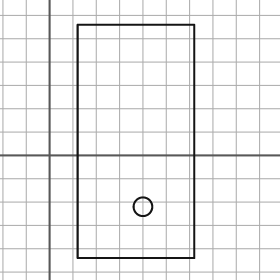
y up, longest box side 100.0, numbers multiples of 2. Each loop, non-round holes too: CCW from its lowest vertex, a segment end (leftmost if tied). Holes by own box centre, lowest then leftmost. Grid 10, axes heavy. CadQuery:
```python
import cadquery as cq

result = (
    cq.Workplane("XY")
    .moveTo(12.0, -44.0)
    .lineTo(62.0, -44.0)
    .lineTo(62.0, 56.0)
    .lineTo(12.0, 56.0)
    .close()
    .moveTo(40.0, -22.0)
    .circle(4.0)
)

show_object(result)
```